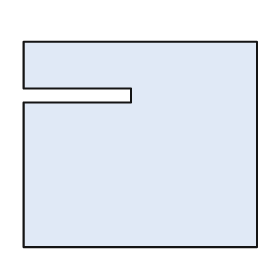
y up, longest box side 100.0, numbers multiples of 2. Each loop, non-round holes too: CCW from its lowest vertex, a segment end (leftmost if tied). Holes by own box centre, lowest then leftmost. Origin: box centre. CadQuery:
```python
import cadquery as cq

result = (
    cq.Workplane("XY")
    .moveTo(-50.0, -44.0)
    .lineTo(50.0, -44.0)
    .lineTo(50.0, 44.0)
    .lineTo(-50.0, 44.0)
    .lineTo(-50.0, 24.0)
    .lineTo(-4.0, 24.0)
    .lineTo(-4.0, 18.0)
    .lineTo(-50.0, 18.0)
    .close()
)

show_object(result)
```